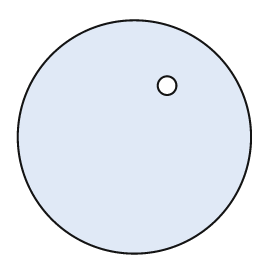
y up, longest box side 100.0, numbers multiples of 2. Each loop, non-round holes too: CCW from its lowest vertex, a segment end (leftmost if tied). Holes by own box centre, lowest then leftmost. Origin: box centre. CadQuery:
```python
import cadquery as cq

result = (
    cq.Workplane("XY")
    .moveTo(0.0, 0.0)
    .circle(50.0)
    .moveTo(14.0, 22.0)
    .circle(4.0)
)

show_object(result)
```